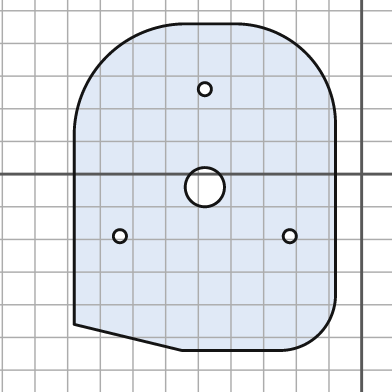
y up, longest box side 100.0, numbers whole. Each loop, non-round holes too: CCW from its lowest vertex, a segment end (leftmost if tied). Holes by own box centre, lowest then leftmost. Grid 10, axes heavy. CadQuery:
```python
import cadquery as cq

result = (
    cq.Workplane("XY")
    .moveTo(-55.0, -54.0)
    .lineTo(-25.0, -54.0)
    .threePointArc((-13.0, -49.0), (-8.0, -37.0))
    .lineTo(-8.0, 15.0)
    .threePointArc((-17.0, 37.0), (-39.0, 46.0))
    .lineTo(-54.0, 46.0)
    .threePointArc((-78.0, 36.0), (-88.0, 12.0))
    .lineTo(-88.0, -46.0)
    .close()
    .moveTo(-74.0, -19.0)
    .circle(2.0)
    .moveTo(-22.0, -19.0)
    .circle(2.0)
    .moveTo(-48.0, -4.0)
    .circle(6.0)
    .moveTo(-48.0, 26.0)
    .circle(2.0)
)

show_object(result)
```